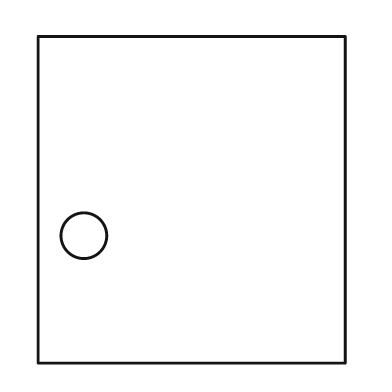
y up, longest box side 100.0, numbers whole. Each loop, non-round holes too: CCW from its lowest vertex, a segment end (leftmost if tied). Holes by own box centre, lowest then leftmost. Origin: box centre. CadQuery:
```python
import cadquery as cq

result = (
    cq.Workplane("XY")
    .moveTo(-47.0, -50.0)
    .lineTo(47.0, -50.0)
    .lineTo(47.0, 50.0)
    .lineTo(-47.0, 50.0)
    .close()
    .moveTo(-33.0, -11.0)
    .circle(7.0)
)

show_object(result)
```